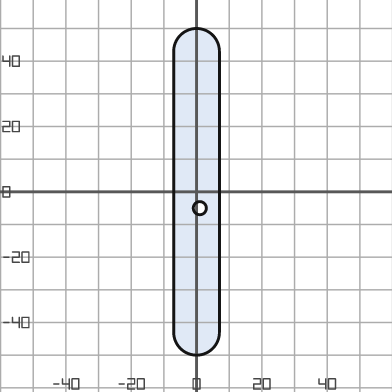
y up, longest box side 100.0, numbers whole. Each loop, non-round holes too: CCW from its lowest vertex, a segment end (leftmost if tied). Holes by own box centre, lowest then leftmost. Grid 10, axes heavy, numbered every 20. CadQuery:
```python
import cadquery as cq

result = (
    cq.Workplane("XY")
    .moveTo(-7.0, -43.0)
    .threePointArc((0.0, -50.0), (7.0, -43.0))
    .lineTo(7.0, 43.0)
    .threePointArc((0.0, 50.0), (-7.0, 43.0))
    .close()
    .moveTo(1.0, -5.0)
    .circle(2.0)
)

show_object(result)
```